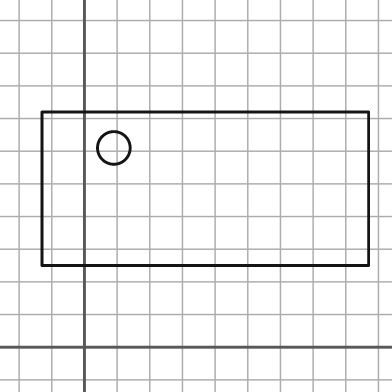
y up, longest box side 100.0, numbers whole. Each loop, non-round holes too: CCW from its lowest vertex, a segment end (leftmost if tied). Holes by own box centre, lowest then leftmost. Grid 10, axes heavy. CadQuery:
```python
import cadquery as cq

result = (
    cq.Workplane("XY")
    .moveTo(-13.0, 25.0)
    .lineTo(87.0, 25.0)
    .lineTo(87.0, 72.0)
    .lineTo(-13.0, 72.0)
    .close()
    .moveTo(9.0, 61.0)
    .circle(5.0)
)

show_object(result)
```